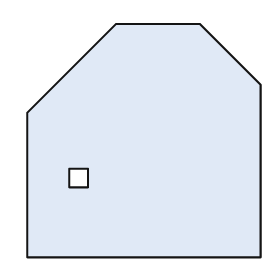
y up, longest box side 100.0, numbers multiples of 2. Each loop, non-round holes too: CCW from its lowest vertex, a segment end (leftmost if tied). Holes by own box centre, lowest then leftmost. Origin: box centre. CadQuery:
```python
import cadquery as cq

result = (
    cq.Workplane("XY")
    .moveTo(-50.0, -50.0)
    .lineTo(50.0, -50.0)
    .lineTo(50.0, 24.0)
    .lineTo(24.0, 50.0)
    .lineTo(-12.0, 50.0)
    .lineTo(-50.0, 12.0)
    .close()
    .moveTo(-32.0, -20.0)
    .lineTo(-24.0, -20.0)
    .lineTo(-24.0, -12.0)
    .lineTo(-32.0, -12.0)
    .close()
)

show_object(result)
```